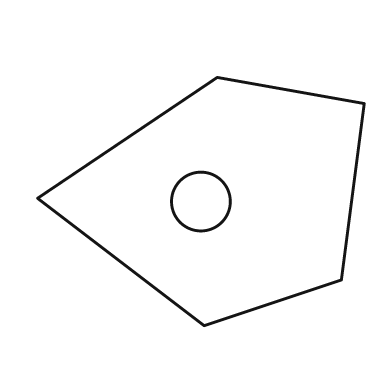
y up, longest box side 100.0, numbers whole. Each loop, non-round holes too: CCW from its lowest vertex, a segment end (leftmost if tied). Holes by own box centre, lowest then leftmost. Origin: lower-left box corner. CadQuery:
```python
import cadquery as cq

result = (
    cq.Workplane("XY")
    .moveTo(51.0, 0.0)
    .lineTo(93.0, 14.0)
    .lineTo(100.0, 68.0)
    .lineTo(55.0, 76.0)
    .lineTo(0.0, 39.0)
    .close()
    .moveTo(50.0, 38.0)
    .circle(9.0)
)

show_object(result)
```